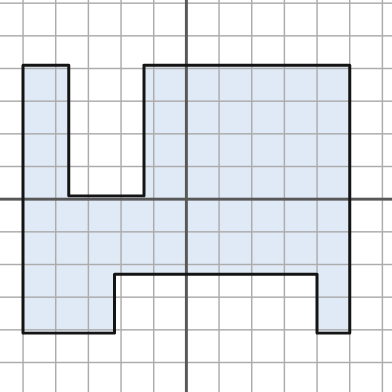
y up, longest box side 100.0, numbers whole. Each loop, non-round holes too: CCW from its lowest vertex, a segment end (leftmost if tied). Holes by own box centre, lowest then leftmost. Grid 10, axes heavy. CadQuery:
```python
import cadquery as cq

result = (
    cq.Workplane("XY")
    .moveTo(-50.0, -41.0)
    .lineTo(-22.0, -41.0)
    .lineTo(-22.0, -23.0)
    .lineTo(40.0, -23.0)
    .lineTo(40.0, -41.0)
    .lineTo(50.0, -41.0)
    .lineTo(50.0, 41.0)
    .lineTo(-13.0, 41.0)
    .lineTo(-13.0, 1.0)
    .lineTo(-36.0, 1.0)
    .lineTo(-36.0, 41.0)
    .lineTo(-50.0, 41.0)
    .close()
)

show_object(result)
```